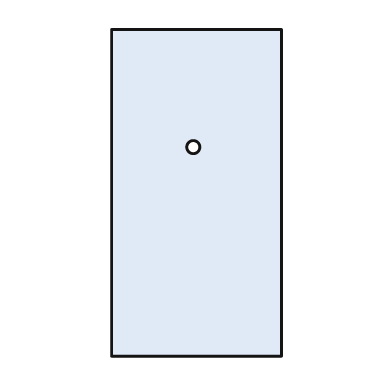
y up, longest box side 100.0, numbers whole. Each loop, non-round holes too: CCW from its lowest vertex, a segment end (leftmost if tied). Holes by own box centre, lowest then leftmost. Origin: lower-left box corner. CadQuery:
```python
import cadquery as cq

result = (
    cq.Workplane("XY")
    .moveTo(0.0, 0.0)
    .lineTo(52.0, 0.0)
    .lineTo(52.0, 100.0)
    .lineTo(0.0, 100.0)
    .close()
    .moveTo(25.0, 64.0)
    .circle(2.0)
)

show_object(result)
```